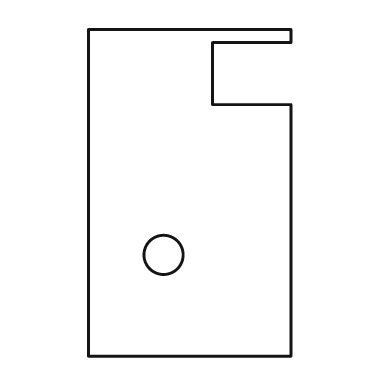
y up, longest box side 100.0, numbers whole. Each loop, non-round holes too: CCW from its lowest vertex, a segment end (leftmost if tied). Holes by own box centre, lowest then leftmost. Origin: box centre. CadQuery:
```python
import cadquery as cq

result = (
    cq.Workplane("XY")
    .moveTo(-31.0, -50.0)
    .lineTo(31.0, -50.0)
    .lineTo(31.0, 27.0)
    .lineTo(7.0, 27.0)
    .lineTo(7.0, 46.0)
    .lineTo(31.0, 46.0)
    .lineTo(31.0, 50.0)
    .lineTo(-31.0, 50.0)
    .close()
    .moveTo(-8.0, -19.0)
    .circle(6.0)
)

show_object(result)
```